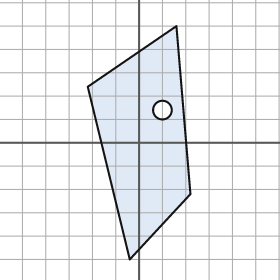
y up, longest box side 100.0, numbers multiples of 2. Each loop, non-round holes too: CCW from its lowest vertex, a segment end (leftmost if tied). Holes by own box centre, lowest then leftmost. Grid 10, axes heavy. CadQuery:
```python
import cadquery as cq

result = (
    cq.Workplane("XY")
    .moveTo(-4.0, -50.0)
    .lineTo(22.0, -22.0)
    .lineTo(16.0, 50.0)
    .lineTo(-22.0, 24.0)
    .close()
    .moveTo(10.0, 14.0)
    .circle(4.0)
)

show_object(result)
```